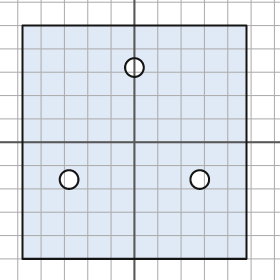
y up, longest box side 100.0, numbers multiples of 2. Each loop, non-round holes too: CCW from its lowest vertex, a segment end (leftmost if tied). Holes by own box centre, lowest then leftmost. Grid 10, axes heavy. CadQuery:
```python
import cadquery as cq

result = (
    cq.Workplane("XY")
    .moveTo(-48.0, -50.0)
    .lineTo(48.0, -50.0)
    .lineTo(48.0, 50.0)
    .lineTo(-48.0, 50.0)
    .close()
    .moveTo(-28.0, -16.0)
    .circle(4.0)
    .moveTo(28.0, -16.0)
    .circle(4.0)
    .moveTo(0.0, 32.0)
    .circle(4.0)
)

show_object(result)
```